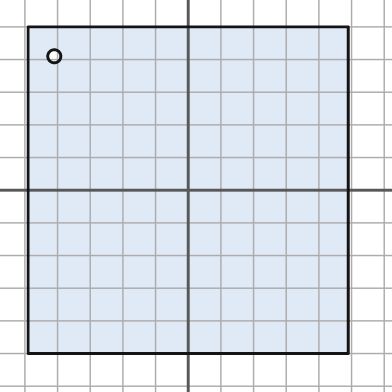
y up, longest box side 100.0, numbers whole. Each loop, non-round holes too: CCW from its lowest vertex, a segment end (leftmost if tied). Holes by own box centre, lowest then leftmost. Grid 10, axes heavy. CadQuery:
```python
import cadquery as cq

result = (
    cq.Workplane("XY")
    .moveTo(-49.0, -50.0)
    .lineTo(49.0, -50.0)
    .lineTo(49.0, 50.0)
    .lineTo(-49.0, 50.0)
    .close()
    .moveTo(-41.0, 41.0)
    .circle(2.0)
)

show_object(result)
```